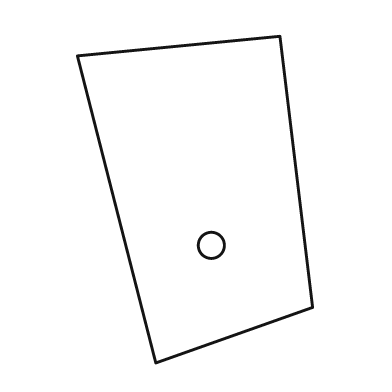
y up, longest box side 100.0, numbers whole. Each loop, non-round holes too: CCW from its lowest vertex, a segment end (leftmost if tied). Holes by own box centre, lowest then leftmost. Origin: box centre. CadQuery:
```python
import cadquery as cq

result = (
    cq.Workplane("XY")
    .moveTo(-12.0, -50.0)
    .lineTo(36.0, -33.0)
    .lineTo(26.0, 50.0)
    .lineTo(-36.0, 44.0)
    .close()
    .moveTo(5.0, -14.0)
    .circle(4.0)
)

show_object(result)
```